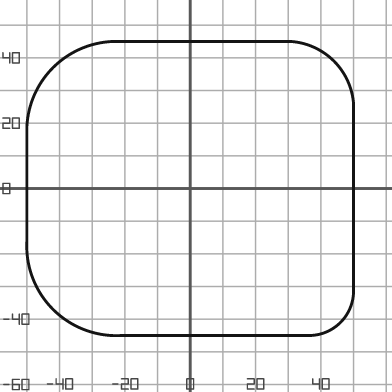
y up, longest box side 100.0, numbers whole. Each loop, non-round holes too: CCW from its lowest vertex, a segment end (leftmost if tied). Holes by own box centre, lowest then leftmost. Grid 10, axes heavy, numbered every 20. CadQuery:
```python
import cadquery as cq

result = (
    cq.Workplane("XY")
    .moveTo(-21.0, -45.0)
    .lineTo(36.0, -45.0)
    .threePointArc((46.0, -41.0), (50.0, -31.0))
    .lineTo(50.0, 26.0)
    .threePointArc((44.0, 39.0), (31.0, 45.0))
    .lineTo(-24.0, 45.0)
    .threePointArc((-42.0, 37.0), (-50.0, 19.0))
    .lineTo(-50.0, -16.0)
    .threePointArc((-42.0, -37.0), (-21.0, -45.0))
    .close()
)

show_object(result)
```